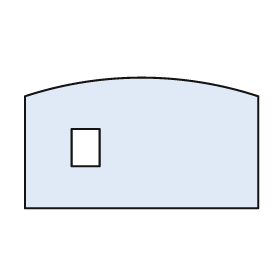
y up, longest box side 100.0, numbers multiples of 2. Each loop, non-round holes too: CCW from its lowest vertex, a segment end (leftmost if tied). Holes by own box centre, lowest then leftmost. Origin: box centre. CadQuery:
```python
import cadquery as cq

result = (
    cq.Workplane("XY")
    .moveTo(-50.0, -28.0)
    .lineTo(50.0, -28.0)
    .lineTo(50.0, 20.0)
    .threePointArc((0.0, 28.0), (-50.0, 20.0))
    .close()
    .moveTo(-30.0, -10.0)
    .lineTo(-18.0, -10.0)
    .lineTo(-18.0, 6.0)
    .lineTo(-30.0, 6.0)
    .close()
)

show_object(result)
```